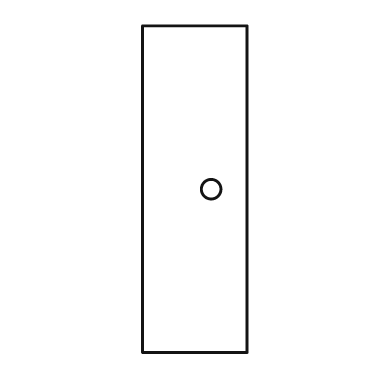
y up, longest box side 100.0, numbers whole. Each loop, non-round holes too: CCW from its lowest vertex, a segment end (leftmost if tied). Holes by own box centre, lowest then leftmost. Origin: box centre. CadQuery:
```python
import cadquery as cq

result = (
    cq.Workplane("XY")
    .moveTo(-16.0, -50.0)
    .lineTo(16.0, -50.0)
    .lineTo(16.0, 50.0)
    .lineTo(-16.0, 50.0)
    .close()
    .moveTo(5.0, 0.0)
    .circle(3.0)
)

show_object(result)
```